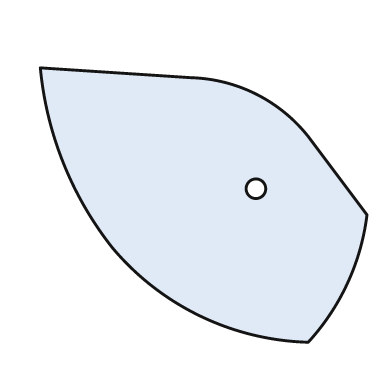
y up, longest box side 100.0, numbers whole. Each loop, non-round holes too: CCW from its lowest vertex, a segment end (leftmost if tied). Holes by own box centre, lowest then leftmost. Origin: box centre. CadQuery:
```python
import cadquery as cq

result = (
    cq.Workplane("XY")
    .moveTo(32.0, -42.0)
    .threePointArc((44.0, -24.0), (50.0, -3.0))
    .lineTo(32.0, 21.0)
    .threePointArc((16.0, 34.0), (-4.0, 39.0))
    .lineTo(-50.0, 42.0)
    .threePointArc((-43.0, 13.0), (-28.0, -13.0))
    .threePointArc((-1.0, -34.0), (32.0, -42.0))
    .close()
    .moveTo(16.0, 5.0)
    .circle(3.0)
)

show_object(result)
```